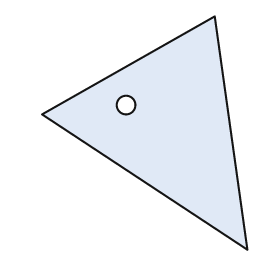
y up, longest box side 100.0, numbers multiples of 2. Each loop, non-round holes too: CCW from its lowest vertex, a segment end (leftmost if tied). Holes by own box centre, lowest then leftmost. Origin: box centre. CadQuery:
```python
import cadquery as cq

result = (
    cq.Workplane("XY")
    .moveTo(44.0, -50.0)
    .lineTo(30.0, 50.0)
    .lineTo(-44.0, 8.0)
    .close()
    .moveTo(-8.0, 12.0)
    .circle(4.0)
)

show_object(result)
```